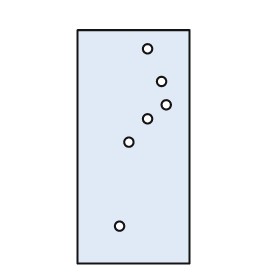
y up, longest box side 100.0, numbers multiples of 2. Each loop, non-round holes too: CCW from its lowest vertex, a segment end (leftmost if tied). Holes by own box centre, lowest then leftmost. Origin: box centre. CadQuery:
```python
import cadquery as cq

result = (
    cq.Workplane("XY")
    .moveTo(-24.0, -50.0)
    .lineTo(24.0, -50.0)
    .lineTo(24.0, 50.0)
    .lineTo(-24.0, 50.0)
    .close()
    .moveTo(-6.0, -34.0)
    .circle(2.0)
    .moveTo(-2.0, 2.0)
    .circle(2.0)
    .moveTo(6.0, 12.0)
    .circle(2.0)
    .moveTo(14.0, 18.0)
    .circle(2.0)
    .moveTo(12.0, 28.0)
    .circle(2.0)
    .moveTo(6.0, 42.0)
    .circle(2.0)
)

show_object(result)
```